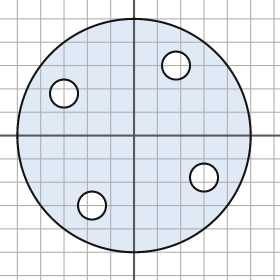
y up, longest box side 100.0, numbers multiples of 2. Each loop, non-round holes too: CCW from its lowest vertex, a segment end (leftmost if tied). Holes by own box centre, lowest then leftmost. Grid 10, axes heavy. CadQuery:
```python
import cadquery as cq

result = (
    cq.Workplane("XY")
    .moveTo(0.0, 0.0)
    .circle(50.0)
    .moveTo(-18.0, -30.0)
    .circle(6.0)
    .moveTo(30.0, -18.0)
    .circle(6.0)
    .moveTo(-30.0, 18.0)
    .circle(6.0)
    .moveTo(18.0, 30.0)
    .circle(6.0)
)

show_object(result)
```